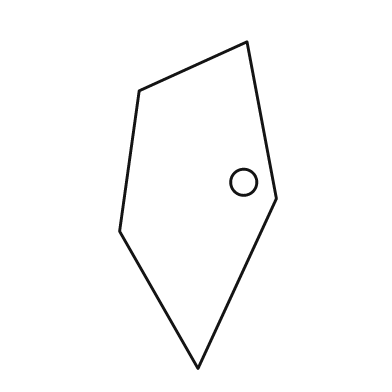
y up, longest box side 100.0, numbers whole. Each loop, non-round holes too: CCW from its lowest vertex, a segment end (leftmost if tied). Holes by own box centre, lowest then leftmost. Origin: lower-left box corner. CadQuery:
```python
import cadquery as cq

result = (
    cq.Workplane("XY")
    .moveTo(24.0, 0.0)
    .lineTo(48.0, 52.0)
    .lineTo(39.0, 100.0)
    .lineTo(6.0, 85.0)
    .lineTo(0.0, 42.0)
    .close()
    .moveTo(38.0, 57.0)
    .circle(4.0)
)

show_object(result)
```